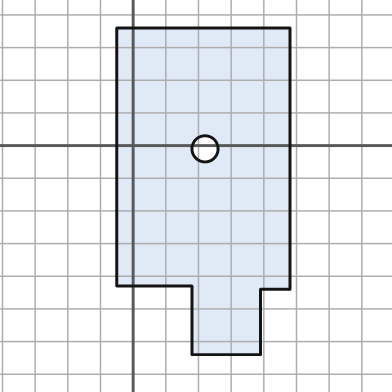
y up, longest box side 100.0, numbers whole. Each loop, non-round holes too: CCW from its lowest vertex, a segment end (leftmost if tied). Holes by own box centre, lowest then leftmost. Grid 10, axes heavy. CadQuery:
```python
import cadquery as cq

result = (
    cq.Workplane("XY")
    .moveTo(18.0, -64.0)
    .lineTo(39.0, -64.0)
    .lineTo(39.0, -44.0)
    .lineTo(48.0, -44.0)
    .lineTo(48.0, 36.0)
    .lineTo(-5.0, 36.0)
    .lineTo(-5.0, -43.0)
    .lineTo(18.0, -43.0)
    .close()
    .moveTo(22.0, -1.0)
    .circle(4.0)
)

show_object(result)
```